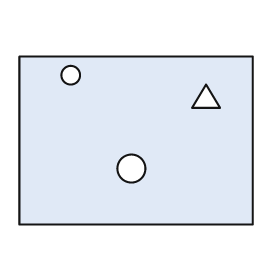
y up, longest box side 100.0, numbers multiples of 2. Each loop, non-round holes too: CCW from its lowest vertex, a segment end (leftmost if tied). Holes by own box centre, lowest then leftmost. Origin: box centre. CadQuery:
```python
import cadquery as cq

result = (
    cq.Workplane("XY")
    .moveTo(-50.0, -36.0)
    .lineTo(50.0, -36.0)
    .lineTo(50.0, 36.0)
    .lineTo(-50.0, 36.0)
    .close()
    .moveTo(-2.0, -12.0)
    .circle(6.0)
    .moveTo(24.0, 14.0)
    .lineTo(36.0, 14.0)
    .lineTo(30.0, 24.0)
    .close()
    .moveTo(-28.0, 28.0)
    .circle(4.0)
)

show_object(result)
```